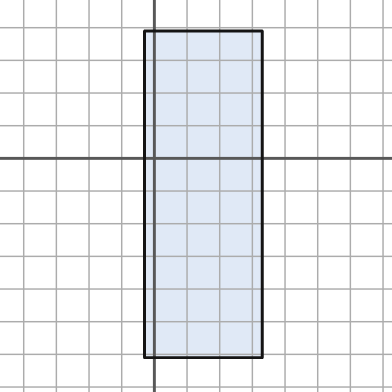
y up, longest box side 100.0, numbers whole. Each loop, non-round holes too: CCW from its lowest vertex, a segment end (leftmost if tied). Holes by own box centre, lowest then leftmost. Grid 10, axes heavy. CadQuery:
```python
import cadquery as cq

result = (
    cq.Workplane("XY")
    .moveTo(-3.0, -61.0)
    .lineTo(33.0, -61.0)
    .lineTo(33.0, 39.0)
    .lineTo(-3.0, 39.0)
    .close()
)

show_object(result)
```